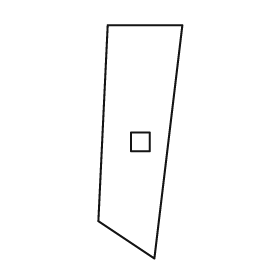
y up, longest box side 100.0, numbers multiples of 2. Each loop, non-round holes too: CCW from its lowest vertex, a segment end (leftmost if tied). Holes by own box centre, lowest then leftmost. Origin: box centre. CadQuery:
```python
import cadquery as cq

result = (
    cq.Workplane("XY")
    .moveTo(6.0, -50.0)
    .lineTo(18.0, 50.0)
    .lineTo(-14.0, 50.0)
    .lineTo(-18.0, -34.0)
    .close()
    .moveTo(-4.0, -4.0)
    .lineTo(4.0, -4.0)
    .lineTo(4.0, 4.0)
    .lineTo(-4.0, 4.0)
    .close()
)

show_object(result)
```